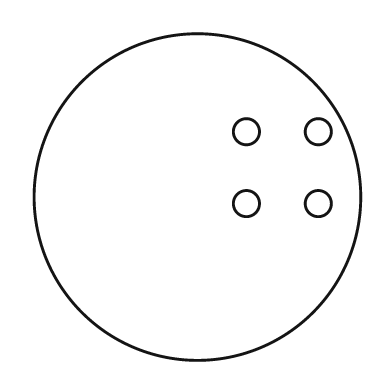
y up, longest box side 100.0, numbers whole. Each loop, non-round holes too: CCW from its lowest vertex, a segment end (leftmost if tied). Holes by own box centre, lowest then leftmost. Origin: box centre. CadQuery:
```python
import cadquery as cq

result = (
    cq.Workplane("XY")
    .moveTo(0.0, 0.0)
    .circle(50.0)
    .moveTo(15.0, -2.0)
    .circle(4.0)
    .moveTo(37.0, -2.0)
    .circle(4.0)
    .moveTo(15.0, 20.0)
    .circle(4.0)
    .moveTo(37.0, 20.0)
    .circle(4.0)
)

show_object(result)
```